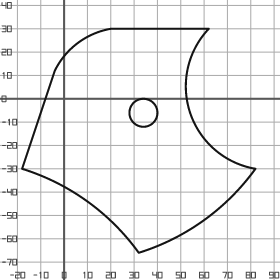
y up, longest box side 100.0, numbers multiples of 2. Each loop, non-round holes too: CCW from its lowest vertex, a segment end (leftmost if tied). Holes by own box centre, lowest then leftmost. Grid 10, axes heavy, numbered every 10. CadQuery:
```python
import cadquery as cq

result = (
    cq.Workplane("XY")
    .moveTo(32.0, -66.0)
    .threePointArc((60.0, -52.0), (82.0, -30.0))
    .threePointArc((54.0, -6.0), (62.0, 30.0))
    .lineTo(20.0, 30.0)
    .threePointArc((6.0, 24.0), (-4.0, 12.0))
    .lineTo(-18.0, -30.0)
    .threePointArc((10.0, -44.0), (32.0, -66.0))
    .close()
    .moveTo(34.0, -6.0)
    .circle(6.0)
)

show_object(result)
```